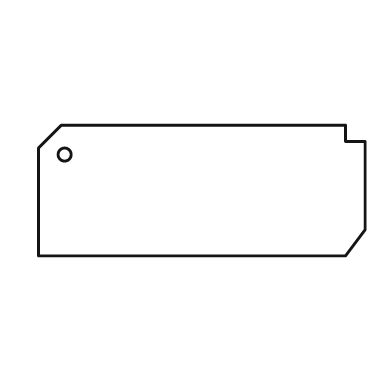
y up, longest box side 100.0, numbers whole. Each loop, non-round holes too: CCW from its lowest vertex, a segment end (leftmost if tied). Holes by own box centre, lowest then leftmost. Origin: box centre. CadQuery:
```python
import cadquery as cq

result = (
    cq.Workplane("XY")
    .moveTo(-50.0, -20.0)
    .lineTo(44.0, -20.0)
    .lineTo(50.0, -12.0)
    .lineTo(50.0, 15.0)
    .lineTo(44.0, 15.0)
    .lineTo(44.0, 20.0)
    .lineTo(-43.0, 20.0)
    .lineTo(-50.0, 13.0)
    .close()
    .moveTo(-42.0, 11.0)
    .circle(2.0)
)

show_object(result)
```